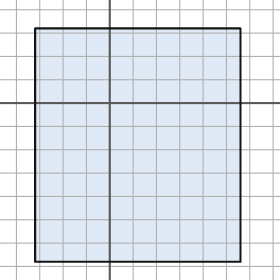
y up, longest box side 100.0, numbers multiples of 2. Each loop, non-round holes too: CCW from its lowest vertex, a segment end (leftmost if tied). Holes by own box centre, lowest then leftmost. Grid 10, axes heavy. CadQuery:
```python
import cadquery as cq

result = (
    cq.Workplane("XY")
    .moveTo(-32.0, -68.0)
    .lineTo(56.0, -68.0)
    .lineTo(56.0, 32.0)
    .lineTo(-32.0, 32.0)
    .close()
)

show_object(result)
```